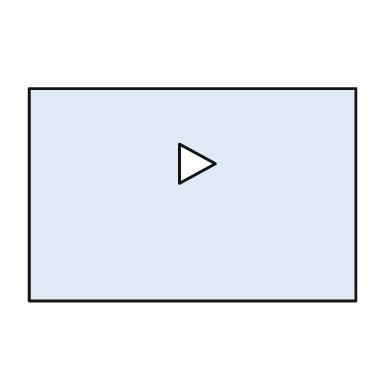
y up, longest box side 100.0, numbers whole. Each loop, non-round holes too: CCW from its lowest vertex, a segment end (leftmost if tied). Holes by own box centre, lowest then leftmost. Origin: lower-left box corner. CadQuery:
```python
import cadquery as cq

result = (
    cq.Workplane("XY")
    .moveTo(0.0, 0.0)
    .lineTo(100.0, 0.0)
    .lineTo(100.0, 65.0)
    .lineTo(0.0, 65.0)
    .close()
    .moveTo(46.0, 36.0)
    .lineTo(57.0, 42.0)
    .lineTo(46.0, 48.0)
    .close()
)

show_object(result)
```